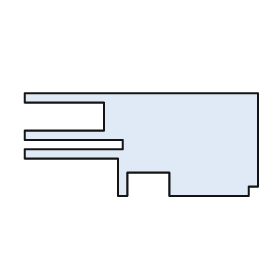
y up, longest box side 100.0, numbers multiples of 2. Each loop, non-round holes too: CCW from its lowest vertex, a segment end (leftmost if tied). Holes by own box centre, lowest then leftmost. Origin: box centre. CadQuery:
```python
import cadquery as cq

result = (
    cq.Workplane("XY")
    .moveTo(-10.0, -22.0)
    .lineTo(-6.0, -22.0)
    .lineTo(-6.0, -12.0)
    .lineTo(12.0, -12.0)
    .lineTo(12.0, -22.0)
    .lineTo(46.0, -22.0)
    .lineTo(46.0, -18.0)
    .lineTo(50.0, -18.0)
    .lineTo(50.0, 22.0)
    .lineTo(-50.0, 22.0)
    .lineTo(-50.0, 18.0)
    .lineTo(-16.0, 18.0)
    .lineTo(-16.0, 6.0)
    .lineTo(-50.0, 6.0)
    .lineTo(-50.0, 2.0)
    .lineTo(-8.0, 2.0)
    .lineTo(-8.0, -2.0)
    .lineTo(-50.0, -2.0)
    .lineTo(-50.0, -6.0)
    .lineTo(-10.0, -6.0)
    .close()
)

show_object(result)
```